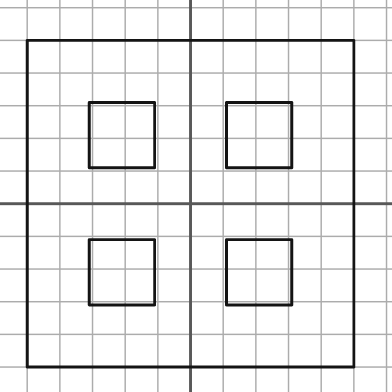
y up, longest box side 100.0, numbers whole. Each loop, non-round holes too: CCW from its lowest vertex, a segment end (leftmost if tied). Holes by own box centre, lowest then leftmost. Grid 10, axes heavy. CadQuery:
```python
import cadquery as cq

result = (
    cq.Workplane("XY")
    .moveTo(-50.0, -50.0)
    .lineTo(50.0, -50.0)
    .lineTo(50.0, 50.0)
    .lineTo(-50.0, 50.0)
    .close()
    .moveTo(-31.0, -31.0)
    .lineTo(-11.0, -31.0)
    .lineTo(-11.0, -11.0)
    .lineTo(-31.0, -11.0)
    .close()
    .moveTo(11.0, -31.0)
    .lineTo(31.0, -31.0)
    .lineTo(31.0, -11.0)
    .lineTo(11.0, -11.0)
    .close()
    .moveTo(-31.0, 11.0)
    .lineTo(-11.0, 11.0)
    .lineTo(-11.0, 31.0)
    .lineTo(-31.0, 31.0)
    .close()
    .moveTo(11.0, 11.0)
    .lineTo(31.0, 11.0)
    .lineTo(31.0, 31.0)
    .lineTo(11.0, 31.0)
    .close()
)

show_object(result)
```